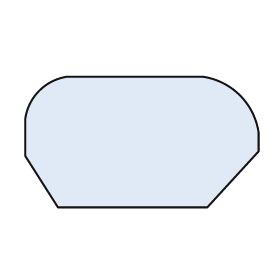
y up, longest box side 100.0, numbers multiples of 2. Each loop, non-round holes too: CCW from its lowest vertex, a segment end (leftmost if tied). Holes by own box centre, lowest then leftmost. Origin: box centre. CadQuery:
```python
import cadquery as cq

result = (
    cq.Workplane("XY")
    .moveTo(-36.0, -28.0)
    .lineTo(28.0, -28.0)
    .lineTo(50.0, -4.0)
    .lineTo(50.0, 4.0)
    .threePointArc((42.0, 20.0), (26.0, 28.0))
    .lineTo(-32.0, 28.0)
    .threePointArc((-44.0, 22.0), (-50.0, 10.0))
    .lineTo(-50.0, -6.0)
    .close()
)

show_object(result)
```